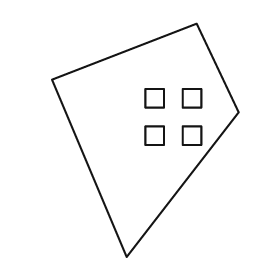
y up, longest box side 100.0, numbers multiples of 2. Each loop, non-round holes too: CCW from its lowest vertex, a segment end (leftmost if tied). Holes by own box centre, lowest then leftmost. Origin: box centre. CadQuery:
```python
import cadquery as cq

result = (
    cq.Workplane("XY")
    .moveTo(-8.0, -50.0)
    .lineTo(40.0, 12.0)
    .lineTo(22.0, 50.0)
    .lineTo(-40.0, 26.0)
    .close()
    .moveTo(0.0, -2.0)
    .lineTo(8.0, -2.0)
    .lineTo(8.0, 6.0)
    .lineTo(0.0, 6.0)
    .close()
    .moveTo(16.0, -2.0)
    .lineTo(24.0, -2.0)
    .lineTo(24.0, 6.0)
    .lineTo(16.0, 6.0)
    .close()
    .moveTo(0.0, 14.0)
    .lineTo(8.0, 14.0)
    .lineTo(8.0, 22.0)
    .lineTo(0.0, 22.0)
    .close()
    .moveTo(16.0, 14.0)
    .lineTo(24.0, 14.0)
    .lineTo(24.0, 22.0)
    .lineTo(16.0, 22.0)
    .close()
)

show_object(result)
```